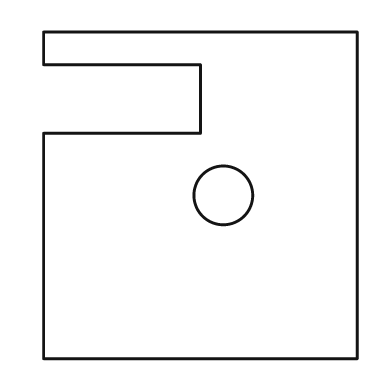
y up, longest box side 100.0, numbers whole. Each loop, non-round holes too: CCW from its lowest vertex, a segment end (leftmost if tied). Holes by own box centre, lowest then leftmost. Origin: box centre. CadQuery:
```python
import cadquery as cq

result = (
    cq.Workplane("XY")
    .moveTo(-48.0, -50.0)
    .lineTo(48.0, -50.0)
    .lineTo(48.0, 50.0)
    .lineTo(-48.0, 50.0)
    .lineTo(-48.0, 40.0)
    .lineTo(0.0, 40.0)
    .lineTo(0.0, 19.0)
    .lineTo(-48.0, 19.0)
    .close()
    .moveTo(7.0, 0.0)
    .circle(9.0)
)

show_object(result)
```